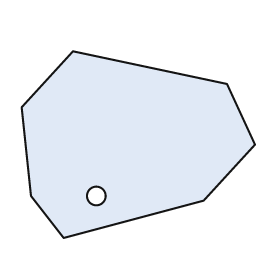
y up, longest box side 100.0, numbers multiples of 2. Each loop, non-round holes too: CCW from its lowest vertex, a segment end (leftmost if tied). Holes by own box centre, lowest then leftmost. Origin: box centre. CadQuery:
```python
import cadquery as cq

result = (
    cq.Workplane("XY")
    .moveTo(-32.0, -40.0)
    .lineTo(28.0, -24.0)
    .lineTo(50.0, 0.0)
    .lineTo(38.0, 26.0)
    .lineTo(-28.0, 40.0)
    .lineTo(-50.0, 16.0)
    .lineTo(-46.0, -22.0)
    .close()
    .moveTo(-18.0, -22.0)
    .circle(4.0)
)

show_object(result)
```